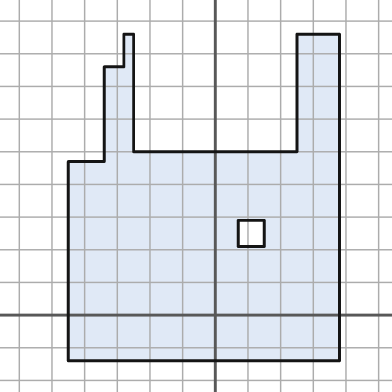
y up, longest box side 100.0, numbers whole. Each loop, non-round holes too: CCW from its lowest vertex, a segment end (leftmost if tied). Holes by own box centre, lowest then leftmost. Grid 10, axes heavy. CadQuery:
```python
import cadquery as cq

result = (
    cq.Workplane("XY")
    .moveTo(-45.0, -14.0)
    .lineTo(38.0, -14.0)
    .lineTo(38.0, 86.0)
    .lineTo(25.0, 86.0)
    .lineTo(25.0, 50.0)
    .lineTo(-25.0, 50.0)
    .lineTo(-25.0, 86.0)
    .lineTo(-28.0, 86.0)
    .lineTo(-28.0, 76.0)
    .lineTo(-34.0, 76.0)
    .lineTo(-34.0, 47.0)
    .lineTo(-45.0, 47.0)
    .close()
    .moveTo(7.0, 21.0)
    .lineTo(15.0, 21.0)
    .lineTo(15.0, 29.0)
    .lineTo(7.0, 29.0)
    .close()
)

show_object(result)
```